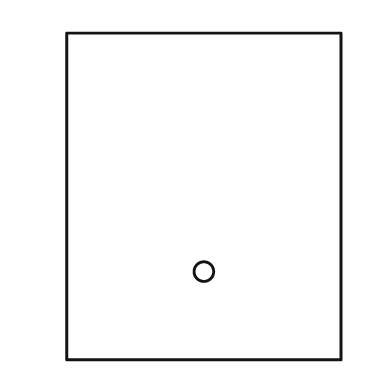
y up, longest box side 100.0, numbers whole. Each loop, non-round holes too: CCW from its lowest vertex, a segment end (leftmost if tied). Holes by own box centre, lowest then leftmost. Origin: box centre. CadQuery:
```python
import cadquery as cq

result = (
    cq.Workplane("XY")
    .moveTo(-42.0, -50.0)
    .lineTo(42.0, -50.0)
    .lineTo(42.0, 50.0)
    .lineTo(-42.0, 50.0)
    .close()
    .moveTo(0.0, -23.0)
    .circle(3.0)
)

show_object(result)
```